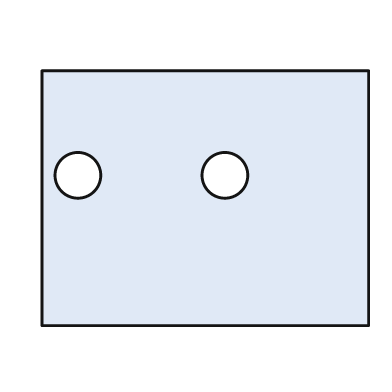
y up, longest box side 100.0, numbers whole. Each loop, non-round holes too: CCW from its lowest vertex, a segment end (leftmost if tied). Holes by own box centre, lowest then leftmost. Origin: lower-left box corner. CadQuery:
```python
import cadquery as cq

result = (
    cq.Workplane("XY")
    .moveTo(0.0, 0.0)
    .lineTo(100.0, 0.0)
    .lineTo(100.0, 78.0)
    .lineTo(0.0, 78.0)
    .close()
    .moveTo(11.0, 46.0)
    .circle(7.0)
    .moveTo(56.0, 46.0)
    .circle(7.0)
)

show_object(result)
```